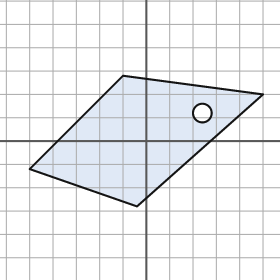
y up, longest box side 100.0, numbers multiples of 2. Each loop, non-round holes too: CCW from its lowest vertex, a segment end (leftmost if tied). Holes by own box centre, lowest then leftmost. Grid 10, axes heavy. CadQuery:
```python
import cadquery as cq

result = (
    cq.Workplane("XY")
    .moveTo(-4.0, -28.0)
    .lineTo(50.0, 20.0)
    .lineTo(-10.0, 28.0)
    .lineTo(-50.0, -12.0)
    .close()
    .moveTo(24.0, 12.0)
    .circle(4.0)
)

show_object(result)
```